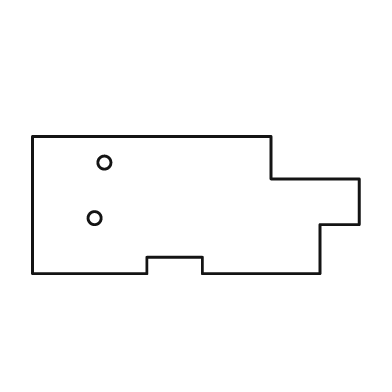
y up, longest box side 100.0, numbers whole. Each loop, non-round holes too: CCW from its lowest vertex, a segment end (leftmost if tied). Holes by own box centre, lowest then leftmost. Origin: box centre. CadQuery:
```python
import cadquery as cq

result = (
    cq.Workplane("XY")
    .moveTo(-50.0, -21.0)
    .lineTo(-15.0, -21.0)
    .lineTo(-15.0, -16.0)
    .lineTo(2.0, -16.0)
    .lineTo(2.0, -21.0)
    .lineTo(38.0, -21.0)
    .lineTo(38.0, -6.0)
    .lineTo(50.0, -6.0)
    .lineTo(50.0, 8.0)
    .lineTo(23.0, 8.0)
    .lineTo(23.0, 21.0)
    .lineTo(-50.0, 21.0)
    .close()
    .moveTo(-31.0, -4.0)
    .circle(2.0)
    .moveTo(-28.0, 13.0)
    .circle(2.0)
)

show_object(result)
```